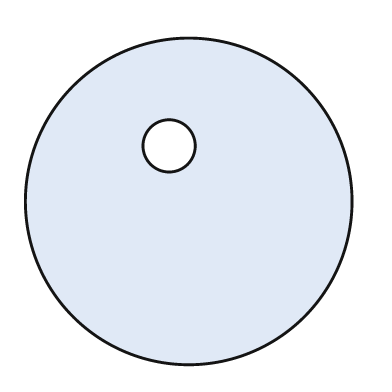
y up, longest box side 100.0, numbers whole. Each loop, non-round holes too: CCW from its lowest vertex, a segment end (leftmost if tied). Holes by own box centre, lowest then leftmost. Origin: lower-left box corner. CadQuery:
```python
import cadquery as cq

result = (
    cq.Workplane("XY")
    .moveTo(50.0, 50.0)
    .circle(50.0)
    .moveTo(44.0, 67.0)
    .circle(8.0)
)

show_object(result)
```